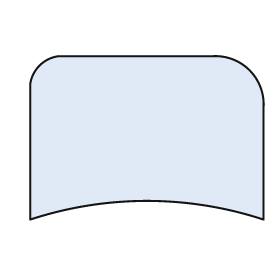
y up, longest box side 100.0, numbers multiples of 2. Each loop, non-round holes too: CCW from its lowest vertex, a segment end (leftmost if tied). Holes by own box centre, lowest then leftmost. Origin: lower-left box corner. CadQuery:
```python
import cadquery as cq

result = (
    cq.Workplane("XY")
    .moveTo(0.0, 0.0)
    .threePointArc((50.0, 8.0), (100.0, 0.0))
    .lineTo(100.0, 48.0)
    .threePointArc((94.0, 64.0), (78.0, 70.0))
    .lineTo(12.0, 70.0)
    .threePointArc((4.0, 66.0), (0.0, 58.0))
    .close()
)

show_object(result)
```